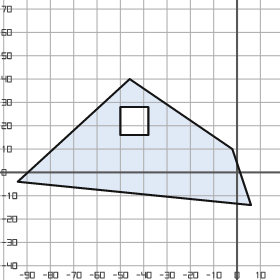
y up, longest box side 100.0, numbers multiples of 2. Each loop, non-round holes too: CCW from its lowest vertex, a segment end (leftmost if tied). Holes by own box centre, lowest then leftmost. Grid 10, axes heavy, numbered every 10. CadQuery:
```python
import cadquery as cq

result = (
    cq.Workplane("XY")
    .moveTo(6.0, -14.0)
    .lineTo(-2.0, 10.0)
    .lineTo(-46.0, 40.0)
    .lineTo(-94.0, -4.0)
    .close()
    .moveTo(-50.0, 16.0)
    .lineTo(-38.0, 16.0)
    .lineTo(-38.0, 28.0)
    .lineTo(-50.0, 28.0)
    .close()
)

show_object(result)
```